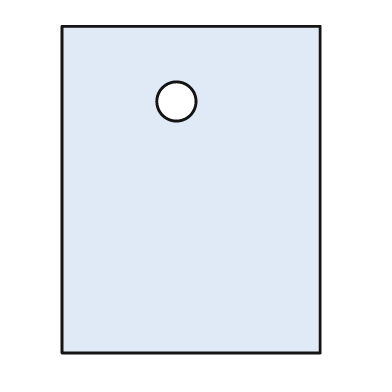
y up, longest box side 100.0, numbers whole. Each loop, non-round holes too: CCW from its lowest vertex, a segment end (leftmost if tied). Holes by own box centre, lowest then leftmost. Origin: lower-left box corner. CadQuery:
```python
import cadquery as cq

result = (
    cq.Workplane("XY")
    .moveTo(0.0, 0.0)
    .lineTo(79.0, 0.0)
    .lineTo(79.0, 100.0)
    .lineTo(0.0, 100.0)
    .close()
    .moveTo(35.0, 77.0)
    .circle(6.0)
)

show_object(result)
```